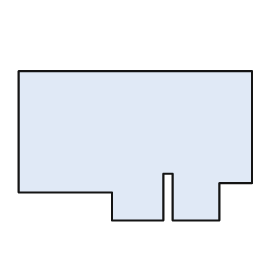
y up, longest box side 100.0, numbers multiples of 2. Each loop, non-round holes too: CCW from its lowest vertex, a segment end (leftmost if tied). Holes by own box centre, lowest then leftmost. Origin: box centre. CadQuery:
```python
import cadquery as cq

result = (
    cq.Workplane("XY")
    .moveTo(-10.0, -32.0)
    .lineTo(12.0, -32.0)
    .lineTo(12.0, -12.0)
    .lineTo(16.0, -12.0)
    .lineTo(16.0, -32.0)
    .lineTo(36.0, -32.0)
    .lineTo(36.0, -16.0)
    .lineTo(50.0, -16.0)
    .lineTo(50.0, 32.0)
    .lineTo(-50.0, 32.0)
    .lineTo(-50.0, -20.0)
    .lineTo(-10.0, -20.0)
    .close()
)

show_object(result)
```